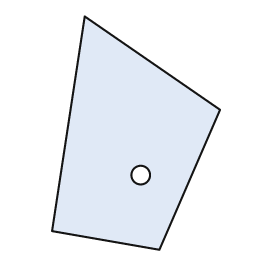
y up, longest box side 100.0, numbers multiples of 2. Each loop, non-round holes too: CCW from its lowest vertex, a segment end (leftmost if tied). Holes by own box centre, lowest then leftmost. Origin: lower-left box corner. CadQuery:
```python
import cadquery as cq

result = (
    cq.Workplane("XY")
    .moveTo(46.0, 0.0)
    .lineTo(72.0, 60.0)
    .lineTo(14.0, 100.0)
    .lineTo(0.0, 8.0)
    .close()
    .moveTo(38.0, 32.0)
    .circle(4.0)
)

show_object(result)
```